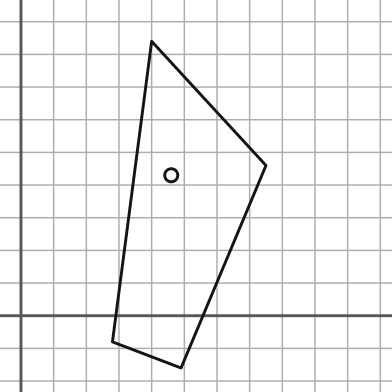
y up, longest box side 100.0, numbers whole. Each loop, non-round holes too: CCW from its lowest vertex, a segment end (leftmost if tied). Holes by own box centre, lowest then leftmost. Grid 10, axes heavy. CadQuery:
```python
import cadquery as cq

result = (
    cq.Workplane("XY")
    .moveTo(49.0, -16.0)
    .lineTo(75.0, 46.0)
    .lineTo(40.0, 84.0)
    .lineTo(28.0, -8.0)
    .close()
    .moveTo(46.0, 43.0)
    .circle(2.0)
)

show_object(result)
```